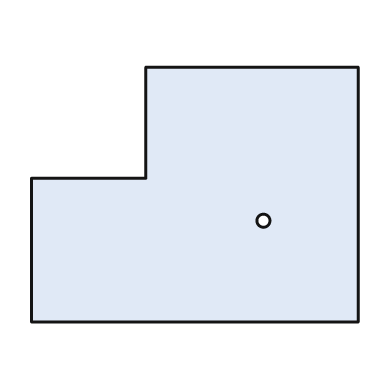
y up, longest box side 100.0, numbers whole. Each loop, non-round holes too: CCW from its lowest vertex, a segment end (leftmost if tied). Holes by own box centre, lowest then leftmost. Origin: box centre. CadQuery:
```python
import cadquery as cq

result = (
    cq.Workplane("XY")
    .moveTo(-50.0, -39.0)
    .lineTo(50.0, -39.0)
    .lineTo(50.0, 39.0)
    .lineTo(-15.0, 39.0)
    .lineTo(-15.0, 5.0)
    .lineTo(-50.0, 5.0)
    .close()
    .moveTo(21.0, -8.0)
    .circle(2.0)
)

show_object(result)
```